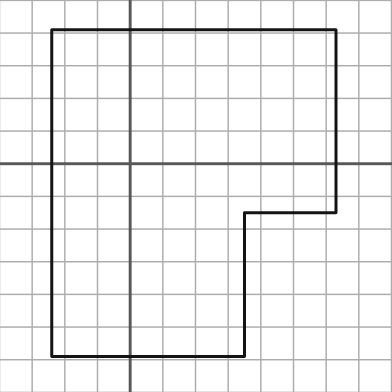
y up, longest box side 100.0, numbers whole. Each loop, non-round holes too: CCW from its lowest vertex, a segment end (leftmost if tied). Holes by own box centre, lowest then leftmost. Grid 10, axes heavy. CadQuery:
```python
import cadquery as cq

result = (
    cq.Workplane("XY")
    .moveTo(-24.0, -59.0)
    .lineTo(35.0, -59.0)
    .lineTo(35.0, -15.0)
    .lineTo(63.0, -15.0)
    .lineTo(63.0, 41.0)
    .lineTo(-24.0, 41.0)
    .close()
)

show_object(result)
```